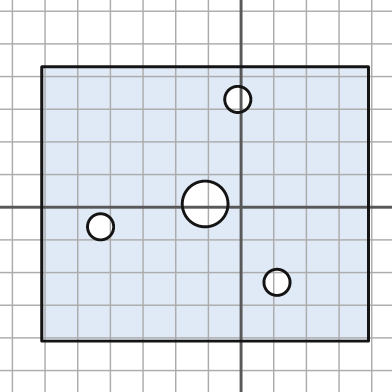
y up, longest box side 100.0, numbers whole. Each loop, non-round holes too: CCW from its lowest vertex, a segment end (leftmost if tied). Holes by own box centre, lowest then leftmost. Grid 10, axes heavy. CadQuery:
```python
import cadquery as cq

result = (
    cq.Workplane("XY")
    .moveTo(-61.0, -41.0)
    .lineTo(39.0, -41.0)
    .lineTo(39.0, 43.0)
    .lineTo(-61.0, 43.0)
    .close()
    .moveTo(11.0, -23.0)
    .circle(4.0)
    .moveTo(-43.0, -6.0)
    .circle(4.0)
    .moveTo(-11.0, 1.0)
    .circle(7.0)
    .moveTo(-1.0, 33.0)
    .circle(4.0)
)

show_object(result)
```